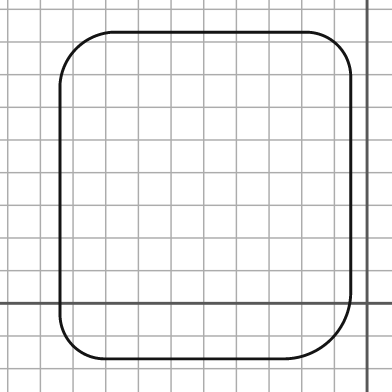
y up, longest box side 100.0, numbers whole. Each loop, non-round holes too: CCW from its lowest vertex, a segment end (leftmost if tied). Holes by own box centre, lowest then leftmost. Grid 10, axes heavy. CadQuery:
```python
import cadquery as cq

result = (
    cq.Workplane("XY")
    .moveTo(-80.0, -17.0)
    .lineTo(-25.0, -17.0)
    .threePointArc((-11.0, -11.0), (-5.0, 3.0))
    .lineTo(-5.0, 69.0)
    .threePointArc((-9.0, 79.0), (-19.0, 83.0))
    .lineTo(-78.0, 83.0)
    .threePointArc((-89.0, 78.0), (-94.0, 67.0))
    .lineTo(-94.0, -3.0)
    .threePointArc((-90.0, -13.0), (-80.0, -17.0))
    .close()
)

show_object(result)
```